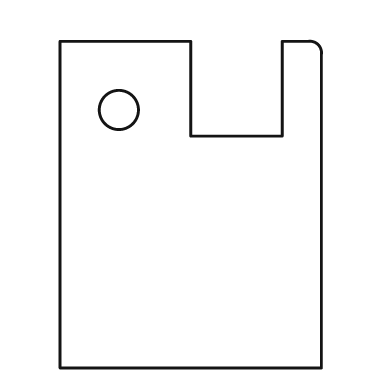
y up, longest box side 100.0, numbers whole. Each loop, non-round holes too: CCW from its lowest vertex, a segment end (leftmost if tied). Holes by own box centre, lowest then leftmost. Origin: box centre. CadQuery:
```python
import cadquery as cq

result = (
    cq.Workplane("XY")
    .moveTo(-40.0, -50.0)
    .lineTo(40.0, -50.0)
    .lineTo(40.0, 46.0)
    .threePointArc((39.0, 49.0), (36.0, 50.0))
    .lineTo(28.0, 50.0)
    .lineTo(28.0, 21.0)
    .lineTo(0.0, 21.0)
    .lineTo(0.0, 50.0)
    .lineTo(-40.0, 50.0)
    .close()
    .moveTo(-22.0, 29.0)
    .circle(6.0)
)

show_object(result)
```